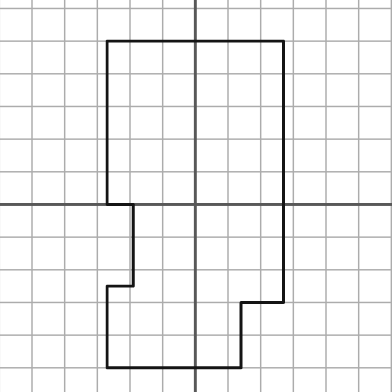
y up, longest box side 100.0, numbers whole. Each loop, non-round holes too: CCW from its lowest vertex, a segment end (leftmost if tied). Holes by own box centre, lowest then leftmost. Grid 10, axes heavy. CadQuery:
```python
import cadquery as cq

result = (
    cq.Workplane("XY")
    .moveTo(-27.0, -50.0)
    .lineTo(14.0, -50.0)
    .lineTo(14.0, -30.0)
    .lineTo(27.0, -30.0)
    .lineTo(27.0, 50.0)
    .lineTo(-27.0, 50.0)
    .lineTo(-27.0, 0.0)
    .lineTo(-19.0, 0.0)
    .lineTo(-19.0, -25.0)
    .lineTo(-27.0, -25.0)
    .close()
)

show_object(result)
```